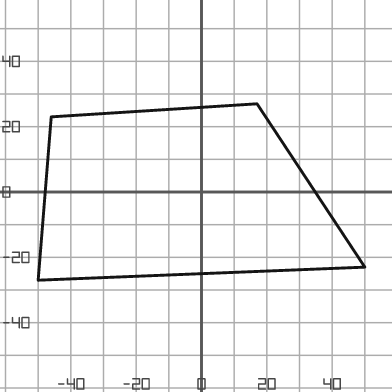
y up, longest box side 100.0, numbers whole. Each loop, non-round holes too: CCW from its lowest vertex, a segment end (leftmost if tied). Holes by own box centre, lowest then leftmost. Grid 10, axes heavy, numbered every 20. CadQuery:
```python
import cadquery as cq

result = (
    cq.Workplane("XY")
    .moveTo(-50.0, -27.0)
    .lineTo(50.0, -23.0)
    .lineTo(17.0, 27.0)
    .lineTo(-46.0, 23.0)
    .close()
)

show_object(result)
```